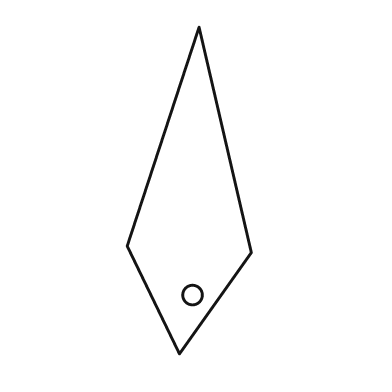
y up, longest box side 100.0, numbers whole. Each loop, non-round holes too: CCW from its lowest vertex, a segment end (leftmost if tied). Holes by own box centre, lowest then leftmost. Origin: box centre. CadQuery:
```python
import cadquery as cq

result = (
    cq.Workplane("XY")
    .moveTo(-3.0, -50.0)
    .lineTo(19.0, -19.0)
    .lineTo(3.0, 50.0)
    .lineTo(-19.0, -17.0)
    .close()
    .moveTo(1.0, -32.0)
    .circle(3.0)
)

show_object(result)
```